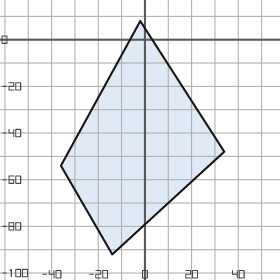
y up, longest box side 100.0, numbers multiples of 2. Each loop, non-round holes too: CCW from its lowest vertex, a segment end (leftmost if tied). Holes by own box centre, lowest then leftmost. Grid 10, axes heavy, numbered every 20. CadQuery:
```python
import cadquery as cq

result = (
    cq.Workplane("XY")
    .moveTo(-14.0, -92.0)
    .lineTo(34.0, -48.0)
    .lineTo(-2.0, 8.0)
    .lineTo(-36.0, -54.0)
    .close()
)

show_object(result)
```